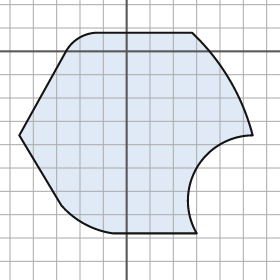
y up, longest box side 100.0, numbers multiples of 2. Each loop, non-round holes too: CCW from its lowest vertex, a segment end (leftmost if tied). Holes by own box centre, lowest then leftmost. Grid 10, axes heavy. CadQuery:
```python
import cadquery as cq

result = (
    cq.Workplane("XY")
    .moveTo(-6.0, -78.0)
    .lineTo(30.0, -78.0)
    .threePointArc((30.0, -50.0), (54.0, -36.0))
    .threePointArc((44.0, -12.0), (28.0, 8.0))
    .lineTo(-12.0, 8.0)
    .threePointArc((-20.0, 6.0), (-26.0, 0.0))
    .lineTo(-46.0, -36.0)
    .lineTo(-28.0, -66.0)
    .threePointArc((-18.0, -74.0), (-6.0, -78.0))
    .close()
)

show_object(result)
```